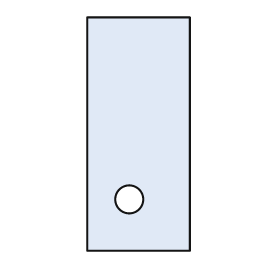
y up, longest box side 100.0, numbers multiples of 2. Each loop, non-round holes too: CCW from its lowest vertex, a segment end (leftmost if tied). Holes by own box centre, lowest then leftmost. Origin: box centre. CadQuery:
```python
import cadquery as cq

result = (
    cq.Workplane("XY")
    .moveTo(-22.0, -50.0)
    .lineTo(22.0, -50.0)
    .lineTo(22.0, 50.0)
    .lineTo(-22.0, 50.0)
    .close()
    .moveTo(-4.0, -28.0)
    .circle(6.0)
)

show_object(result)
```